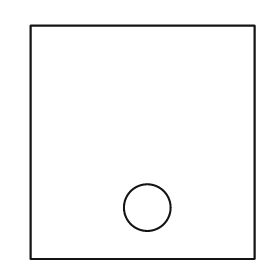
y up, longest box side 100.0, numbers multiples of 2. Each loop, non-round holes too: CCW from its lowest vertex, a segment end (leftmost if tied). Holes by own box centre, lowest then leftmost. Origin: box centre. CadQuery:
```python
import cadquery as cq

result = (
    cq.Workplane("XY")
    .moveTo(-48.0, -50.0)
    .lineTo(48.0, -50.0)
    .lineTo(48.0, 50.0)
    .lineTo(-48.0, 50.0)
    .close()
    .moveTo(2.0, -28.0)
    .circle(10.0)
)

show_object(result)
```